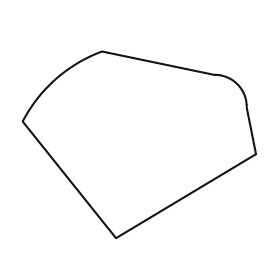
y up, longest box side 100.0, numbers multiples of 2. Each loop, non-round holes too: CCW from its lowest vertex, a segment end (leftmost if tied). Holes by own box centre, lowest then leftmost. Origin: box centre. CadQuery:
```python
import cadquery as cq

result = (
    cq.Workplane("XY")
    .moveTo(-10.0, -40.0)
    .lineTo(50.0, -4.0)
    .lineTo(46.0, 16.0)
    .threePointArc((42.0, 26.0), (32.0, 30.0))
    .lineTo(-16.0, 40.0)
    .threePointArc((-36.0, 28.0), (-50.0, 10.0))
    .close()
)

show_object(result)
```